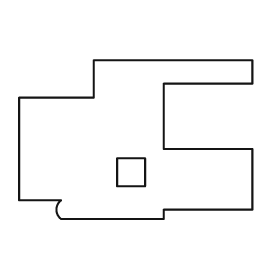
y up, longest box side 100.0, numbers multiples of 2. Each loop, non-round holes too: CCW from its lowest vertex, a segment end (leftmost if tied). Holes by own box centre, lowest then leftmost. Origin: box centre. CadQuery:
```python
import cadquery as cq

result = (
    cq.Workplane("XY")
    .moveTo(-32.0, -34.0)
    .lineTo(12.0, -34.0)
    .lineTo(12.0, -30.0)
    .lineTo(50.0, -30.0)
    .lineTo(50.0, -4.0)
    .lineTo(12.0, -4.0)
    .lineTo(12.0, 24.0)
    .lineTo(50.0, 24.0)
    .lineTo(50.0, 34.0)
    .lineTo(-18.0, 34.0)
    .lineTo(-18.0, 18.0)
    .lineTo(-50.0, 18.0)
    .lineTo(-50.0, -26.0)
    .lineTo(-32.0, -26.0)
    .threePointArc((-34.0, -30.0), (-32.0, -34.0))
    .close()
    .moveTo(-8.0, -20.0)
    .lineTo(4.0, -20.0)
    .lineTo(4.0, -8.0)
    .lineTo(-8.0, -8.0)
    .close()
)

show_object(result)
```